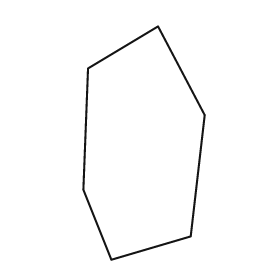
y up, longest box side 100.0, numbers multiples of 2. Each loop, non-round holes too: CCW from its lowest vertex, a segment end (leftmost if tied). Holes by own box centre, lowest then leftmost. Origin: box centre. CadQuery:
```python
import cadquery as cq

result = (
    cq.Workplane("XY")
    .moveTo(-14.0, -50.0)
    .lineTo(20.0, -40.0)
    .lineTo(26.0, 12.0)
    .lineTo(6.0, 50.0)
    .lineTo(-24.0, 32.0)
    .lineTo(-26.0, -20.0)
    .close()
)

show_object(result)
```